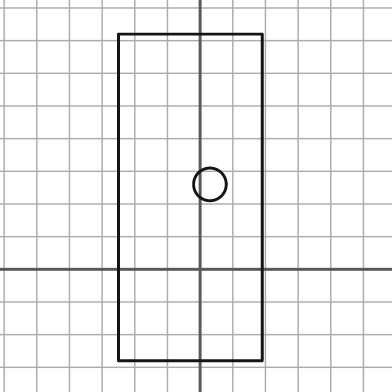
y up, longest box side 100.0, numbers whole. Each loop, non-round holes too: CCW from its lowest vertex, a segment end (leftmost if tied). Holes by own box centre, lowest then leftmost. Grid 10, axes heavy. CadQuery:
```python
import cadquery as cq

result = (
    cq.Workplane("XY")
    .moveTo(-25.0, -28.0)
    .lineTo(19.0, -28.0)
    .lineTo(19.0, 72.0)
    .lineTo(-25.0, 72.0)
    .close()
    .moveTo(3.0, 26.0)
    .circle(5.0)
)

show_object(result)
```